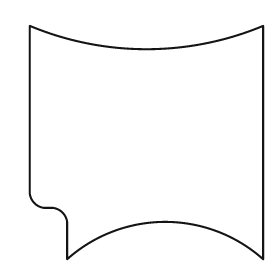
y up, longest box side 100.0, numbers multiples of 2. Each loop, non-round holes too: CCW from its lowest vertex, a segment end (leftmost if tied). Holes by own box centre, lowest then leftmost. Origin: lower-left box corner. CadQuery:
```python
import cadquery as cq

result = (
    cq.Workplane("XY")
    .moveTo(16.0, 0.0)
    .threePointArc((58.0, 16.0), (100.0, 0.0))
    .lineTo(100.0, 100.0)
    .threePointArc((50.0, 90.0), (0.0, 100.0))
    .lineTo(0.0, 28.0)
    .threePointArc((2.0, 24.0), (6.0, 22.0))
    .lineTo(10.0, 22.0)
    .threePointArc((14.0, 20.0), (16.0, 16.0))
    .close()
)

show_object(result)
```